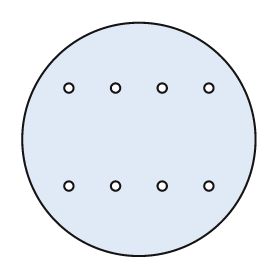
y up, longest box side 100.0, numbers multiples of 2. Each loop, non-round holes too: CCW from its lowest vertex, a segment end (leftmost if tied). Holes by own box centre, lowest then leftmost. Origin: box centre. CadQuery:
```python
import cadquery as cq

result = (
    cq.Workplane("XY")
    .moveTo(0.0, 0.0)
    .circle(50.0)
    .moveTo(-30.0, -20.0)
    .circle(2.0)
    .moveTo(-10.0, -20.0)
    .circle(2.0)
    .moveTo(10.0, -20.0)
    .circle(2.0)
    .moveTo(30.0, -20.0)
    .circle(2.0)
    .moveTo(-30.0, 22.0)
    .circle(2.0)
    .moveTo(-10.0, 22.0)
    .circle(2.0)
    .moveTo(10.0, 22.0)
    .circle(2.0)
    .moveTo(30.0, 22.0)
    .circle(2.0)
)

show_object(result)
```